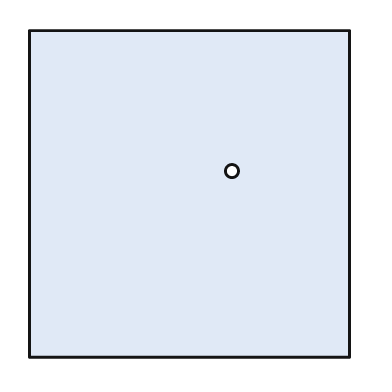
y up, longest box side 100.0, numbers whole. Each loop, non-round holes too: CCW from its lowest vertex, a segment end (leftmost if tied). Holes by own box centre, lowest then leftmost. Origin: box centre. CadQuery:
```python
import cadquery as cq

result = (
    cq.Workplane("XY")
    .moveTo(-49.0, -50.0)
    .lineTo(49.0, -50.0)
    .lineTo(49.0, 50.0)
    .lineTo(-49.0, 50.0)
    .close()
    .moveTo(13.0, 7.0)
    .circle(2.0)
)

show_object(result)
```